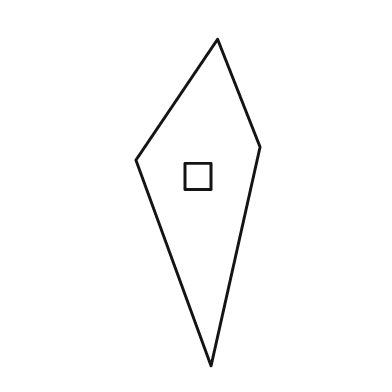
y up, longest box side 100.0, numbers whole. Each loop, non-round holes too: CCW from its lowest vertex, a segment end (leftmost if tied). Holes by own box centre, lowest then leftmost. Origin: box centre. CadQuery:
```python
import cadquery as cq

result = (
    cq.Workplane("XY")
    .moveTo(4.0, -50.0)
    .lineTo(19.0, 17.0)
    .lineTo(6.0, 50.0)
    .lineTo(-19.0, 13.0)
    .close()
    .moveTo(-4.0, 4.0)
    .lineTo(4.0, 4.0)
    .lineTo(4.0, 12.0)
    .lineTo(-4.0, 12.0)
    .close()
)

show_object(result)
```